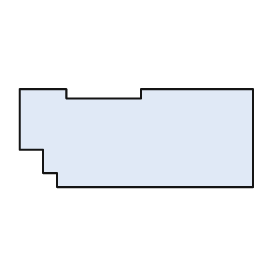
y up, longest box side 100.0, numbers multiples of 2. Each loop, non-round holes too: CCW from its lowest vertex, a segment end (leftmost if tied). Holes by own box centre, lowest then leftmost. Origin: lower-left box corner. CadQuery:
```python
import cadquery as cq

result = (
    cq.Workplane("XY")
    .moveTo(16.0, 0.0)
    .lineTo(100.0, 0.0)
    .lineTo(100.0, 42.0)
    .lineTo(52.0, 42.0)
    .lineTo(52.0, 38.0)
    .lineTo(20.0, 38.0)
    .lineTo(20.0, 42.0)
    .lineTo(0.0, 42.0)
    .lineTo(0.0, 16.0)
    .lineTo(10.0, 16.0)
    .lineTo(10.0, 6.0)
    .lineTo(16.0, 6.0)
    .close()
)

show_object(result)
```